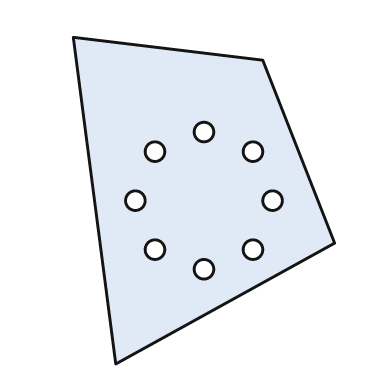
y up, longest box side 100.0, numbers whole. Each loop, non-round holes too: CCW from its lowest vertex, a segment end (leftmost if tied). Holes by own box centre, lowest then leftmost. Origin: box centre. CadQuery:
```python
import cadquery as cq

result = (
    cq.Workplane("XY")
    .moveTo(-27.0, -50.0)
    .lineTo(40.0, -13.0)
    .lineTo(18.0, 43.0)
    .lineTo(-40.0, 50.0)
    .close()
    .moveTo(0.0, -21.0)
    .circle(3.0)
    .moveTo(-15.0, -15.0)
    .circle(3.0)
    .moveTo(15.0, -15.0)
    .circle(3.0)
    .moveTo(-21.0, 0.0)
    .circle(3.0)
    .moveTo(21.0, 0.0)
    .circle(3.0)
    .moveTo(-15.0, 15.0)
    .circle(3.0)
    .moveTo(15.0, 15.0)
    .circle(3.0)
    .moveTo(0.0, 21.0)
    .circle(3.0)
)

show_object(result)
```